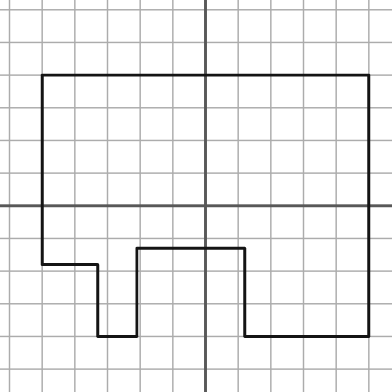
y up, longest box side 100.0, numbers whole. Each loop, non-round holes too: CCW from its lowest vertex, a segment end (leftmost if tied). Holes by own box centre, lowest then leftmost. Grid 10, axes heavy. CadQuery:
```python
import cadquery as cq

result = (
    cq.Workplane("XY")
    .moveTo(-33.0, -40.0)
    .lineTo(-21.0, -40.0)
    .lineTo(-21.0, -13.0)
    .lineTo(12.0, -13.0)
    .lineTo(12.0, -40.0)
    .lineTo(50.0, -40.0)
    .lineTo(50.0, 40.0)
    .lineTo(-50.0, 40.0)
    .lineTo(-50.0, -18.0)
    .lineTo(-33.0, -18.0)
    .close()
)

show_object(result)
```